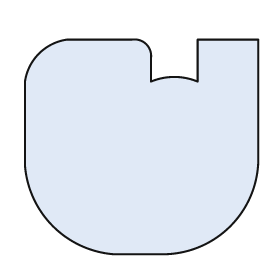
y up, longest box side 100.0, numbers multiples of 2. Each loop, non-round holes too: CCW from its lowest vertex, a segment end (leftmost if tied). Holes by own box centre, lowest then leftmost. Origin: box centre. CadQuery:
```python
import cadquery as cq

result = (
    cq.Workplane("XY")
    .moveTo(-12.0, -46.0)
    .lineTo(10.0, -46.0)
    .threePointArc((38.0, -34.0), (50.0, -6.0))
    .lineTo(50.0, 46.0)
    .lineTo(24.0, 46.0)
    .lineTo(24.0, 28.0)
    .threePointArc((14.0, 30.0), (4.0, 28.0))
    .lineTo(4.0, 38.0)
    .threePointArc((2.0, 44.0), (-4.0, 46.0))
    .lineTo(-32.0, 46.0)
    .threePointArc((-44.0, 40.0), (-50.0, 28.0))
    .lineTo(-50.0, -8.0)
    .threePointArc((-38.0, -34.0), (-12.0, -46.0))
    .close()
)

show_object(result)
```